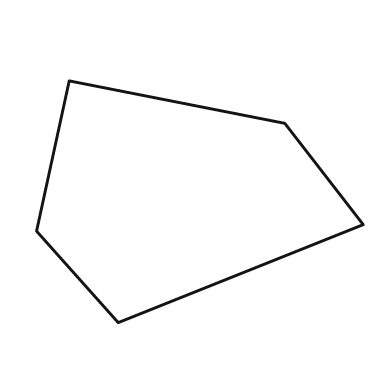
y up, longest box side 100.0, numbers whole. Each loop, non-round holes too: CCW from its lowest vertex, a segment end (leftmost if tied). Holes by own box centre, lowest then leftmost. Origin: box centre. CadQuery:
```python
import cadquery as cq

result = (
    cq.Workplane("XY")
    .moveTo(-25.0, -37.0)
    .lineTo(50.0, -7.0)
    .lineTo(26.0, 24.0)
    .lineTo(-40.0, 37.0)
    .lineTo(-50.0, -9.0)
    .close()
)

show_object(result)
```